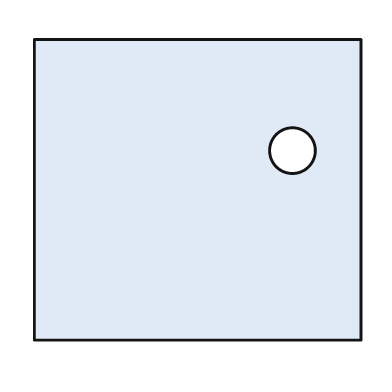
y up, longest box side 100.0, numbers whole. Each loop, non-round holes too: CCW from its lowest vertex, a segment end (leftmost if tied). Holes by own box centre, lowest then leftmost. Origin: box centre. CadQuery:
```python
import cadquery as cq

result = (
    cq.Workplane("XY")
    .moveTo(-50.0, -46.0)
    .lineTo(50.0, -46.0)
    .lineTo(50.0, 46.0)
    .lineTo(-50.0, 46.0)
    .close()
    .moveTo(29.0, 12.0)
    .circle(7.0)
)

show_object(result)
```